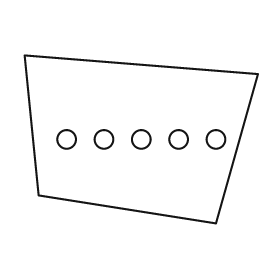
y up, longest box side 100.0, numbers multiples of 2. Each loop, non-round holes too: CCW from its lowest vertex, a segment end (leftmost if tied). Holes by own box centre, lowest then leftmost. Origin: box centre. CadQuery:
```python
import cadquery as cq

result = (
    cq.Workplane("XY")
    .moveTo(32.0, -36.0)
    .lineTo(50.0, 28.0)
    .lineTo(-50.0, 36.0)
    .lineTo(-44.0, -24.0)
    .close()
    .moveTo(-32.0, 0.0)
    .circle(4.0)
    .moveTo(-16.0, 0.0)
    .circle(4.0)
    .moveTo(0.0, 0.0)
    .circle(4.0)
    .moveTo(16.0, 0.0)
    .circle(4.0)
    .moveTo(32.0, 0.0)
    .circle(4.0)
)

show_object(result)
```